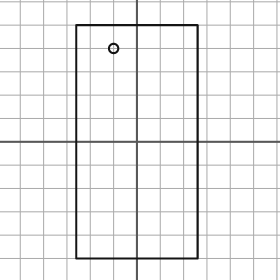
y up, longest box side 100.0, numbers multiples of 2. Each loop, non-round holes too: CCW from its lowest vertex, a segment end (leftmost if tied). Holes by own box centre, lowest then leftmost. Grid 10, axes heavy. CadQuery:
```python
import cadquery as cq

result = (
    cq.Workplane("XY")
    .moveTo(-26.0, -50.0)
    .lineTo(26.0, -50.0)
    .lineTo(26.0, 50.0)
    .lineTo(-26.0, 50.0)
    .close()
    .moveTo(-10.0, 40.0)
    .circle(2.0)
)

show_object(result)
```